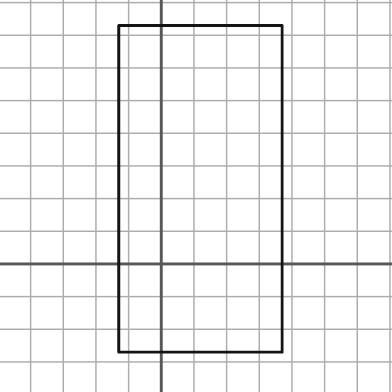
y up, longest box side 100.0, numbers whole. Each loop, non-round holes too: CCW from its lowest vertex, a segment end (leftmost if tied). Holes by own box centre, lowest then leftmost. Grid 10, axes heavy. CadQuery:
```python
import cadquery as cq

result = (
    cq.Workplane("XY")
    .moveTo(-13.0, -27.0)
    .lineTo(37.0, -27.0)
    .lineTo(37.0, 73.0)
    .lineTo(-13.0, 73.0)
    .close()
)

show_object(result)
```